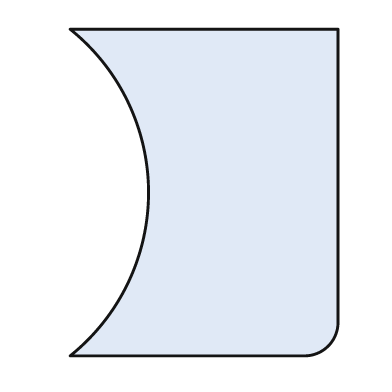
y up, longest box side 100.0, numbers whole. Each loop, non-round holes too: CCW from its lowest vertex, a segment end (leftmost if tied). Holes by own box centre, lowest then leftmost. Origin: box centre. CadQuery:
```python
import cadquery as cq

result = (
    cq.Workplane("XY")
    .moveTo(-41.0, -50.0)
    .lineTo(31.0, -50.0)
    .threePointArc((38.0, -47.0), (41.0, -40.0))
    .lineTo(41.0, 50.0)
    .lineTo(-41.0, 50.0)
    .threePointArc((-17.0, 0.0), (-41.0, -50.0))
    .close()
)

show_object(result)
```